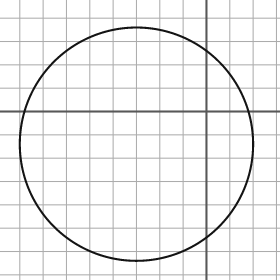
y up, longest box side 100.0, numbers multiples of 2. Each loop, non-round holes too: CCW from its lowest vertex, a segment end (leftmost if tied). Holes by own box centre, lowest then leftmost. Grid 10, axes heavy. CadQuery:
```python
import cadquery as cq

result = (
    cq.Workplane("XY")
    .moveTo(-30.0, -14.0)
    .circle(50.0)
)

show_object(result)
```